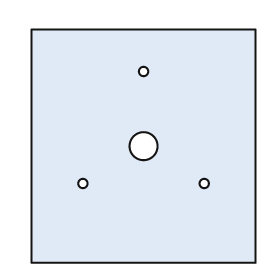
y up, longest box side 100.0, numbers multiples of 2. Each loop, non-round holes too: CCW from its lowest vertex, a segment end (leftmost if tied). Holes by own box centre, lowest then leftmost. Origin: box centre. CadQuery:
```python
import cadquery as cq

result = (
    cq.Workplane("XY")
    .moveTo(-48.0, -50.0)
    .lineTo(48.0, -50.0)
    .lineTo(48.0, 50.0)
    .lineTo(-48.0, 50.0)
    .close()
    .moveTo(-26.0, -16.0)
    .circle(2.0)
    .moveTo(26.0, -16.0)
    .circle(2.0)
    .moveTo(0.0, 0.0)
    .circle(6.0)
    .moveTo(0.0, 32.0)
    .circle(2.0)
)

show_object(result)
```